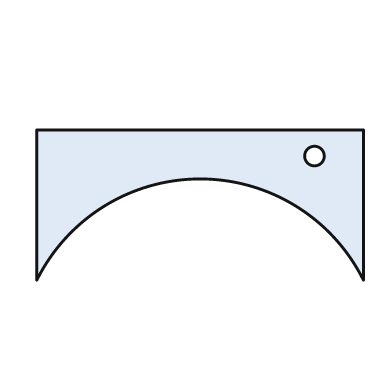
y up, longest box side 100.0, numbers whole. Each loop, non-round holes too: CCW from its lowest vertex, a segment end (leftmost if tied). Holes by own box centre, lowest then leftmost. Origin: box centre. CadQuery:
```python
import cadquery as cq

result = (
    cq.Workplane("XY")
    .moveTo(-50.0, -23.0)
    .threePointArc((0.0, 8.0), (50.0, -23.0))
    .lineTo(50.0, 23.0)
    .lineTo(-50.0, 23.0)
    .close()
    .moveTo(35.0, 15.0)
    .circle(3.0)
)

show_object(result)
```